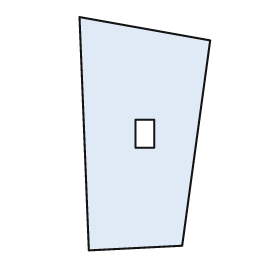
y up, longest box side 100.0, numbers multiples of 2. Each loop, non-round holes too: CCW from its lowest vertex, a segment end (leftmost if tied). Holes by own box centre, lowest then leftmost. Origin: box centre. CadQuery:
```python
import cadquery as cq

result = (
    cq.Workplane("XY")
    .moveTo(-24.0, -50.0)
    .lineTo(16.0, -48.0)
    .lineTo(28.0, 40.0)
    .lineTo(-28.0, 50.0)
    .close()
    .moveTo(-4.0, -6.0)
    .lineTo(4.0, -6.0)
    .lineTo(4.0, 6.0)
    .lineTo(-4.0, 6.0)
    .close()
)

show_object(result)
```